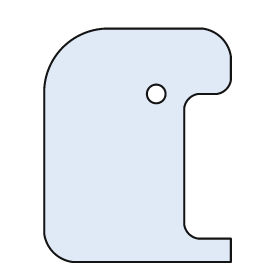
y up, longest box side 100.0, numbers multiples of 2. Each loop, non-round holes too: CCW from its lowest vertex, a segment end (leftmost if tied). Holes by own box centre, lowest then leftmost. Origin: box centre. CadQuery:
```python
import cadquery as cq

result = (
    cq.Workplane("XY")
    .moveTo(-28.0, -50.0)
    .lineTo(40.0, -50.0)
    .lineTo(40.0, -40.0)
    .lineTo(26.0, -40.0)
    .threePointArc((22.0, -38.0), (20.0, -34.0))
    .lineTo(20.0, 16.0)
    .threePointArc((22.0, 20.0), (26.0, 22.0))
    .lineTo(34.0, 22.0)
    .threePointArc((38.0, 24.0), (40.0, 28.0))
    .lineTo(40.0, 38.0)
    .threePointArc((36.0, 46.0), (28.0, 50.0))
    .lineTo(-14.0, 50.0)
    .threePointArc((-32.0, 42.0), (-40.0, 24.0))
    .lineTo(-40.0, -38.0)
    .threePointArc((-36.0, -46.0), (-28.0, -50.0))
    .close()
    .moveTo(8.0, 22.0)
    .circle(4.0)
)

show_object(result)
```